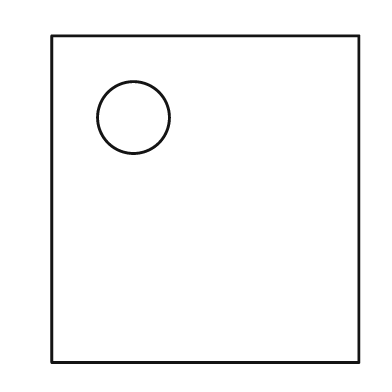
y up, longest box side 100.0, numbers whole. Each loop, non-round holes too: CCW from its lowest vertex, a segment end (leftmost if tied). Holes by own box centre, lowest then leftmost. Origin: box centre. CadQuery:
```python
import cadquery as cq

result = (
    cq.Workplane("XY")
    .moveTo(-47.0, -50.0)
    .lineTo(47.0, -50.0)
    .lineTo(47.0, 50.0)
    .lineTo(-47.0, 50.0)
    .close()
    .moveTo(-22.0, 25.0)
    .circle(11.0)
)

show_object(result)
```